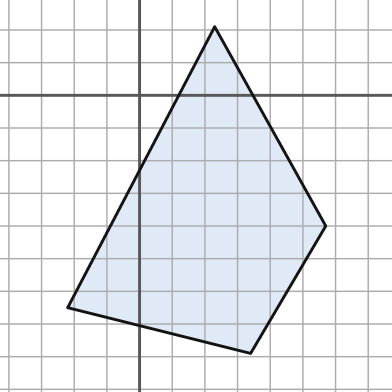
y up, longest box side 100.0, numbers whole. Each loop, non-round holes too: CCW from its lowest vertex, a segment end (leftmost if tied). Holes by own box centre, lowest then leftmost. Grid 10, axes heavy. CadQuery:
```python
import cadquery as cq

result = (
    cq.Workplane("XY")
    .moveTo(34.0, -79.0)
    .lineTo(57.0, -40.0)
    .lineTo(23.0, 21.0)
    .lineTo(-22.0, -65.0)
    .close()
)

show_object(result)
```